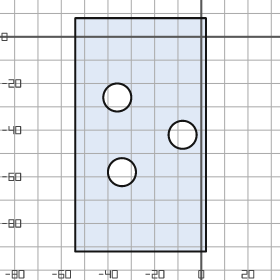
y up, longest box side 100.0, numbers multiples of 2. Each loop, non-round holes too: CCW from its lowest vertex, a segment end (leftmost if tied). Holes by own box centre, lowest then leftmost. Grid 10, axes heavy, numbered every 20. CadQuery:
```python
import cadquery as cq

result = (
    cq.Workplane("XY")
    .moveTo(-54.0, -92.0)
    .lineTo(2.0, -92.0)
    .lineTo(2.0, 8.0)
    .lineTo(-54.0, 8.0)
    .close()
    .moveTo(-34.0, -58.0)
    .circle(6.0)
    .moveTo(-8.0, -42.0)
    .circle(6.0)
    .moveTo(-36.0, -26.0)
    .circle(6.0)
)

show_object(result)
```